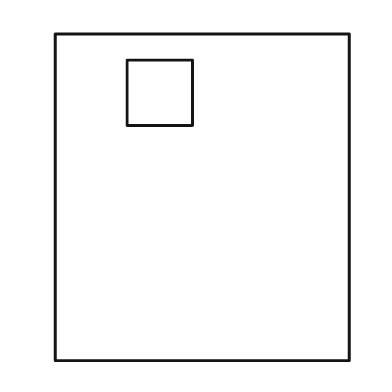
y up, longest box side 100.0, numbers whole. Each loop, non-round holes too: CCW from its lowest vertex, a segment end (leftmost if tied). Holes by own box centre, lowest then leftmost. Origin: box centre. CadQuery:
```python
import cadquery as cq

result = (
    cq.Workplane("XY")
    .moveTo(-45.0, -50.0)
    .lineTo(45.0, -50.0)
    .lineTo(45.0, 50.0)
    .lineTo(-45.0, 50.0)
    .close()
    .moveTo(-23.0, 22.0)
    .lineTo(-3.0, 22.0)
    .lineTo(-3.0, 42.0)
    .lineTo(-23.0, 42.0)
    .close()
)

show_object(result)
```